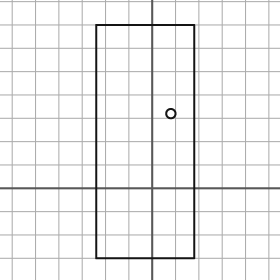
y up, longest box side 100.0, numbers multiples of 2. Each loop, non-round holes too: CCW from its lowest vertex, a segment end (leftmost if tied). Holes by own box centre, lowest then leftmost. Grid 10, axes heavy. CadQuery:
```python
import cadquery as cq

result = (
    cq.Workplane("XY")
    .moveTo(-24.0, -30.0)
    .lineTo(18.0, -30.0)
    .lineTo(18.0, 70.0)
    .lineTo(-24.0, 70.0)
    .close()
    .moveTo(8.0, 32.0)
    .circle(2.0)
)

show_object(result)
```